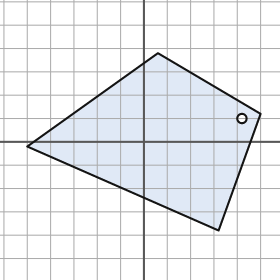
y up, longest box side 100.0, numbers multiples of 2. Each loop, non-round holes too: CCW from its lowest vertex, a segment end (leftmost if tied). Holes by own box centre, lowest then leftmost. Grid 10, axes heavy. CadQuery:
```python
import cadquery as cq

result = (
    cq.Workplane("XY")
    .moveTo(32.0, -38.0)
    .lineTo(50.0, 12.0)
    .lineTo(6.0, 38.0)
    .lineTo(-50.0, -2.0)
    .close()
    .moveTo(42.0, 10.0)
    .circle(2.0)
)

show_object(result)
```